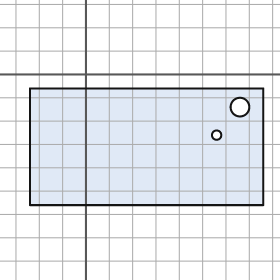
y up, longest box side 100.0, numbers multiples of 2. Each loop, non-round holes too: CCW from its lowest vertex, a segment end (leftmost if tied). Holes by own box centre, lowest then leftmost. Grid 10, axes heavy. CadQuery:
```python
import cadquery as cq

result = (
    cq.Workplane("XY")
    .moveTo(-24.0, -56.0)
    .lineTo(76.0, -56.0)
    .lineTo(76.0, -6.0)
    .lineTo(-24.0, -6.0)
    .close()
    .moveTo(56.0, -26.0)
    .circle(2.0)
    .moveTo(66.0, -14.0)
    .circle(4.0)
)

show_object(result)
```